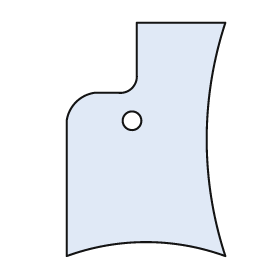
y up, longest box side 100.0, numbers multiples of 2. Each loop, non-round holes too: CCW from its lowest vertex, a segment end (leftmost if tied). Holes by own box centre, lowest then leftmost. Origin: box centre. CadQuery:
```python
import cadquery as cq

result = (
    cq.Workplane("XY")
    .moveTo(-34.0, -50.0)
    .threePointArc((0.0, -44.0), (34.0, -50.0))
    .threePointArc((26.0, 0.0), (34.0, 50.0))
    .lineTo(-4.0, 50.0)
    .lineTo(-4.0, 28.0)
    .threePointArc((-6.0, 22.0), (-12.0, 20.0))
    .lineTo(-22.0, 20.0)
    .threePointArc((-30.0, 16.0), (-34.0, 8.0))
    .close()
    .moveTo(-6.0, 8.0)
    .circle(4.0)
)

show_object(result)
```